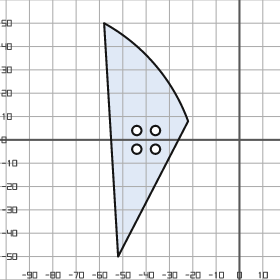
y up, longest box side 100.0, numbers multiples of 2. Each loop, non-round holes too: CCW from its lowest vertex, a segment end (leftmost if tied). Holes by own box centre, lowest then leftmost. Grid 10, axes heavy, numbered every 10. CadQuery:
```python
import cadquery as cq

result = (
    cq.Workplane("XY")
    .moveTo(-52.0, -50.0)
    .lineTo(-22.0, 8.0)
    .threePointArc((-36.0, 32.0), (-58.0, 50.0))
    .close()
    .moveTo(-44.0, -4.0)
    .circle(2.0)
    .moveTo(-36.0, -4.0)
    .circle(2.0)
    .moveTo(-44.0, 4.0)
    .circle(2.0)
    .moveTo(-36.0, 4.0)
    .circle(2.0)
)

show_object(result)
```